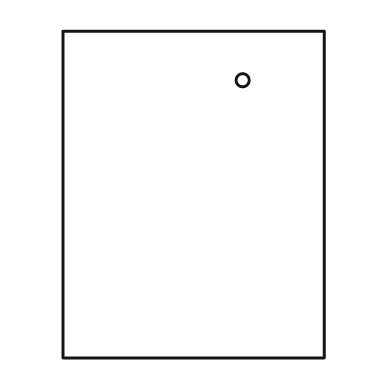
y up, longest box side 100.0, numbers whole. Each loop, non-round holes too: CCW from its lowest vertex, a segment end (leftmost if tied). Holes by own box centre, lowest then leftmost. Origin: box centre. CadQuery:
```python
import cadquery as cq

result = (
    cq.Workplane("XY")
    .moveTo(-40.0, -50.0)
    .lineTo(40.0, -50.0)
    .lineTo(40.0, 50.0)
    .lineTo(-40.0, 50.0)
    .close()
    .moveTo(15.0, 35.0)
    .circle(2.0)
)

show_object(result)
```